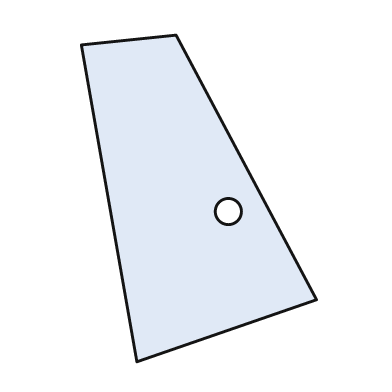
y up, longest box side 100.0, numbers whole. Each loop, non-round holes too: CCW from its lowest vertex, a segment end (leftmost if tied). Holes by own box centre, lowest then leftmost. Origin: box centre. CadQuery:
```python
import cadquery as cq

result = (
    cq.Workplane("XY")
    .moveTo(-19.0, -50.0)
    .lineTo(36.0, -31.0)
    .lineTo(-7.0, 50.0)
    .lineTo(-36.0, 47.0)
    .close()
    .moveTo(9.0, -4.0)
    .circle(4.0)
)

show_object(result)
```